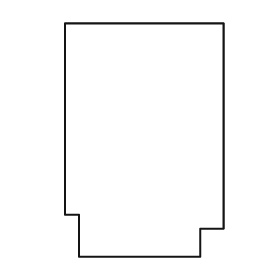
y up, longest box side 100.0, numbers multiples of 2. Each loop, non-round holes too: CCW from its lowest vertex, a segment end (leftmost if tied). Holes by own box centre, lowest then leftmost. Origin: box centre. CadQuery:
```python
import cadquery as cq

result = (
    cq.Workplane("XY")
    .moveTo(-28.0, -50.0)
    .lineTo(24.0, -50.0)
    .lineTo(24.0, -38.0)
    .lineTo(34.0, -38.0)
    .lineTo(34.0, 50.0)
    .lineTo(-34.0, 50.0)
    .lineTo(-34.0, -32.0)
    .lineTo(-28.0, -32.0)
    .close()
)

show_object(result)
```